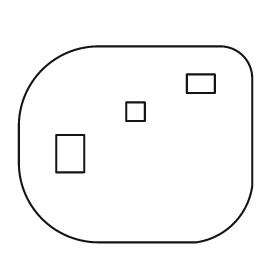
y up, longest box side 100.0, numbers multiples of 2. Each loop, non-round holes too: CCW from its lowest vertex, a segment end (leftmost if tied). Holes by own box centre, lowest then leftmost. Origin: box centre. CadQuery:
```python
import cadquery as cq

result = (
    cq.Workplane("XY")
    .moveTo(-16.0, -42.0)
    .lineTo(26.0, -42.0)
    .threePointArc((42.0, -34.0), (50.0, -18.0))
    .lineTo(50.0, 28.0)
    .threePointArc((46.0, 38.0), (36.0, 42.0))
    .lineTo(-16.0, 42.0)
    .threePointArc((-40.0, 32.0), (-50.0, 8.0))
    .lineTo(-50.0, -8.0)
    .threePointArc((-40.0, -32.0), (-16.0, -42.0))
    .close()
    .moveTo(-34.0, -12.0)
    .lineTo(-22.0, -12.0)
    .lineTo(-22.0, 4.0)
    .lineTo(-34.0, 4.0)
    .close()
    .moveTo(-4.0, 10.0)
    .lineTo(4.0, 10.0)
    .lineTo(4.0, 18.0)
    .lineTo(-4.0, 18.0)
    .close()
    .moveTo(22.0, 22.0)
    .lineTo(34.0, 22.0)
    .lineTo(34.0, 30.0)
    .lineTo(22.0, 30.0)
    .close()
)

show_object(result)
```